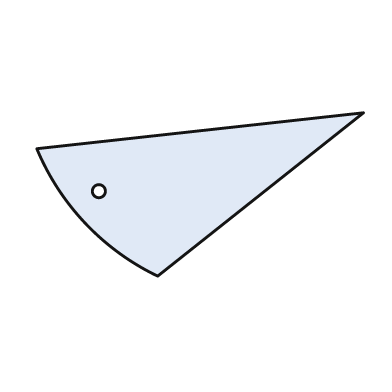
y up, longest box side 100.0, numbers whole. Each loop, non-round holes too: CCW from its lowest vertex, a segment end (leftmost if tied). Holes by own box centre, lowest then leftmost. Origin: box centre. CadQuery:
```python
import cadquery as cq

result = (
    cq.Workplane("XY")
    .moveTo(-13.0, -25.0)
    .lineTo(50.0, 25.0)
    .lineTo(-50.0, 14.0)
    .threePointArc((-35.0, -9.0), (-13.0, -25.0))
    .close()
    .moveTo(-31.0, 1.0)
    .circle(2.0)
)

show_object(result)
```